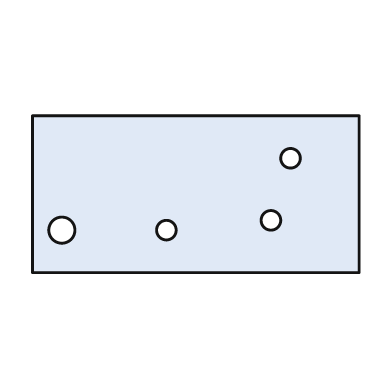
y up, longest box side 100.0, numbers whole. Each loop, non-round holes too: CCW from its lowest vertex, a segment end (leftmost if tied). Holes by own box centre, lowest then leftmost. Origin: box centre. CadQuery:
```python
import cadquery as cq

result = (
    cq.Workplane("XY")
    .moveTo(-50.0, -24.0)
    .lineTo(50.0, -24.0)
    .lineTo(50.0, 24.0)
    .lineTo(-50.0, 24.0)
    .close()
    .moveTo(-41.0, -11.0)
    .circle(4.0)
    .moveTo(-9.0, -11.0)
    .circle(3.0)
    .moveTo(23.0, -8.0)
    .circle(3.0)
    .moveTo(29.0, 11.0)
    .circle(3.0)
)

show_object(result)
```